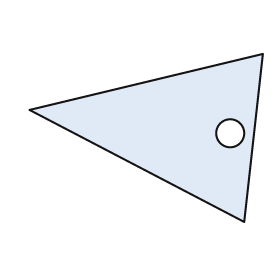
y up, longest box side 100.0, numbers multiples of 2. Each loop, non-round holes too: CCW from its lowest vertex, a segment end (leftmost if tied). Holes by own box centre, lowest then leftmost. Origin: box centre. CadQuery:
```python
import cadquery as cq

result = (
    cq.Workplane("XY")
    .moveTo(42.0, -36.0)
    .lineTo(50.0, 36.0)
    .lineTo(-50.0, 12.0)
    .close()
    .moveTo(36.0, 2.0)
    .circle(6.0)
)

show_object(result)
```